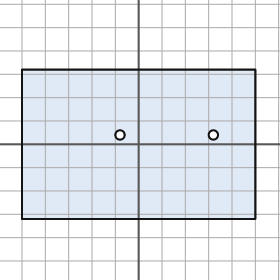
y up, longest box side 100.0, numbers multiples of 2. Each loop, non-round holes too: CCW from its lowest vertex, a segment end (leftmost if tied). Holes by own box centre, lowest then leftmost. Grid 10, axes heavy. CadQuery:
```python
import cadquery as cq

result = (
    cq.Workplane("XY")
    .moveTo(-50.0, -32.0)
    .lineTo(50.0, -32.0)
    .lineTo(50.0, 32.0)
    .lineTo(-50.0, 32.0)
    .close()
    .moveTo(-8.0, 4.0)
    .circle(2.0)
    .moveTo(32.0, 4.0)
    .circle(2.0)
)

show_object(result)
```